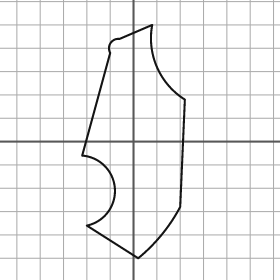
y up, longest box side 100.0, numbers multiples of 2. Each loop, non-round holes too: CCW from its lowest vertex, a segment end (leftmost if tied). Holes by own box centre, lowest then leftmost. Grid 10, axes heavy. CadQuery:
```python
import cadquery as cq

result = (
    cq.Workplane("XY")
    .moveTo(2.0, -50.0)
    .threePointArc((12.0, -40.0), (20.0, -28.0))
    .lineTo(22.0, 18.0)
    .threePointArc((10.0, 32.0), (8.0, 50.0))
    .lineTo(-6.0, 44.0)
    .threePointArc((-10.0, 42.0), (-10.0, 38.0))
    .lineTo(-22.0, -6.0)
    .threePointArc((-8.0, -20.0), (-20.0, -36.0))
    .close()
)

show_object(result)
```